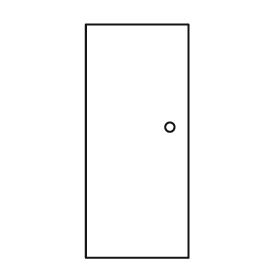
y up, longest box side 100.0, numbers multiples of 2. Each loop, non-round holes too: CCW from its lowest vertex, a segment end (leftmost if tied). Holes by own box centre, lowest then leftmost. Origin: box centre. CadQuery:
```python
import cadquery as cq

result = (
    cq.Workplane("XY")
    .moveTo(-22.0, -50.0)
    .lineTo(22.0, -50.0)
    .lineTo(22.0, 50.0)
    .lineTo(-22.0, 50.0)
    .close()
    .moveTo(14.0, 6.0)
    .circle(2.0)
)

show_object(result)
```